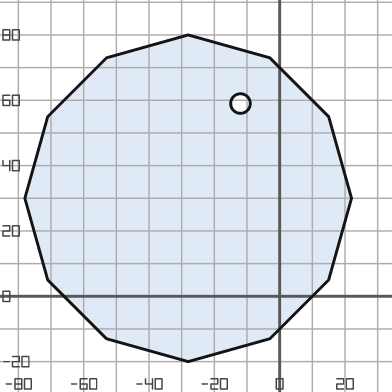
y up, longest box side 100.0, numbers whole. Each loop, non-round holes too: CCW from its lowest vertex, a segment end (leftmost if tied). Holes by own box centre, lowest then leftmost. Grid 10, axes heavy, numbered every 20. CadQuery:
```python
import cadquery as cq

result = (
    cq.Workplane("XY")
    .moveTo(-28.0, -20.0)
    .lineTo(-3.0, -13.0)
    .lineTo(15.0, 5.0)
    .lineTo(22.0, 30.0)
    .lineTo(15.0, 55.0)
    .lineTo(-3.0, 73.0)
    .lineTo(-28.0, 80.0)
    .lineTo(-53.0, 73.0)
    .lineTo(-71.0, 55.0)
    .lineTo(-78.0, 30.0)
    .lineTo(-71.0, 5.0)
    .lineTo(-53.0, -13.0)
    .close()
    .moveTo(-12.0, 59.0)
    .circle(3.0)
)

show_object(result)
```